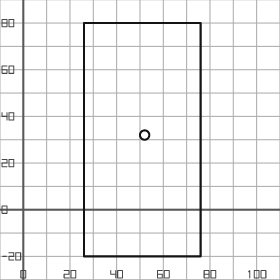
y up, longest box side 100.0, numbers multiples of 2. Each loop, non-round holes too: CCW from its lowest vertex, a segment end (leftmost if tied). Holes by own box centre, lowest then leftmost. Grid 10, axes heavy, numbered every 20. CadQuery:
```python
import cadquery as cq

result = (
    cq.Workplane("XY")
    .moveTo(26.0, -20.0)
    .lineTo(76.0, -20.0)
    .lineTo(76.0, 80.0)
    .lineTo(26.0, 80.0)
    .close()
    .moveTo(52.0, 32.0)
    .circle(2.0)
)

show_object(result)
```